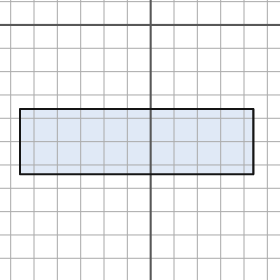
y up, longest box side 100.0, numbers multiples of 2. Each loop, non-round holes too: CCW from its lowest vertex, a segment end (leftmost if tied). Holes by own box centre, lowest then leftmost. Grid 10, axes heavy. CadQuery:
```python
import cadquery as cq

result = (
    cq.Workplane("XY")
    .moveTo(-56.0, -64.0)
    .lineTo(44.0, -64.0)
    .lineTo(44.0, -36.0)
    .lineTo(-56.0, -36.0)
    .close()
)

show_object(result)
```